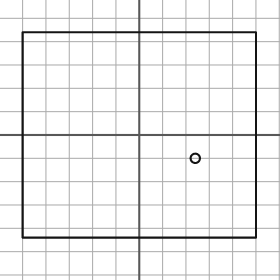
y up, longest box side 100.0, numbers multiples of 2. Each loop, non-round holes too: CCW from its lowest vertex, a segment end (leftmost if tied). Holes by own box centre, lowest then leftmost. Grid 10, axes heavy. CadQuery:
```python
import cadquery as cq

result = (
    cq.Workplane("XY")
    .moveTo(-50.0, -44.0)
    .lineTo(50.0, -44.0)
    .lineTo(50.0, 44.0)
    .lineTo(-50.0, 44.0)
    .close()
    .moveTo(24.0, -10.0)
    .circle(2.0)
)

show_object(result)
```